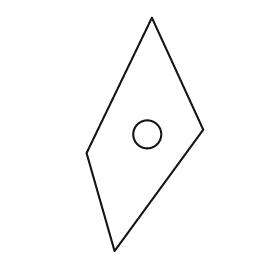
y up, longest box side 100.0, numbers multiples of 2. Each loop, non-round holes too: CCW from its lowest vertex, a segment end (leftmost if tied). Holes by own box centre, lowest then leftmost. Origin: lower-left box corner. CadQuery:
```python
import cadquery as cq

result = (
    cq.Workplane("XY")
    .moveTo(12.0, 0.0)
    .lineTo(50.0, 52.0)
    .lineTo(28.0, 100.0)
    .lineTo(0.0, 42.0)
    .close()
    .moveTo(26.0, 50.0)
    .circle(6.0)
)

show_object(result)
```